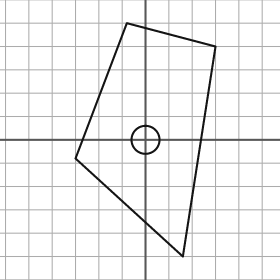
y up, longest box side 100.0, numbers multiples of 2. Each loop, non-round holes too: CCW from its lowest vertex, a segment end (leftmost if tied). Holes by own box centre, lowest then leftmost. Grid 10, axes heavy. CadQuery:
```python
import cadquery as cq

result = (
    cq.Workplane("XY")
    .moveTo(16.0, -50.0)
    .lineTo(30.0, 40.0)
    .lineTo(-8.0, 50.0)
    .lineTo(-30.0, -8.0)
    .close()
    .moveTo(0.0, 0.0)
    .circle(6.0)
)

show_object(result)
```